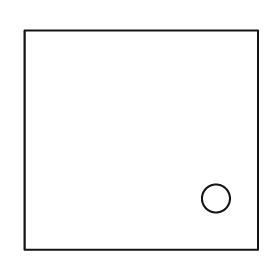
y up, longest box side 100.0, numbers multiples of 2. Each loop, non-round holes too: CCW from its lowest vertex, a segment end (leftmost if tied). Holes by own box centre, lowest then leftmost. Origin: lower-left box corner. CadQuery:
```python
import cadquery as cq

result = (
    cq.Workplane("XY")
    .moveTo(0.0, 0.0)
    .lineTo(100.0, 0.0)
    .lineTo(100.0, 94.0)
    .lineTo(0.0, 94.0)
    .close()
    .moveTo(82.0, 22.0)
    .circle(6.0)
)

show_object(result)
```